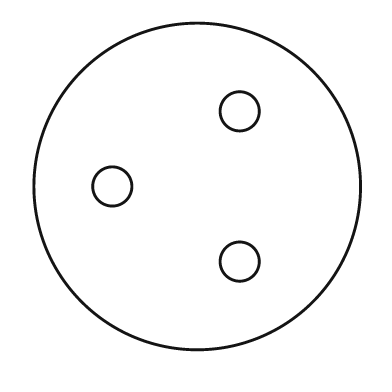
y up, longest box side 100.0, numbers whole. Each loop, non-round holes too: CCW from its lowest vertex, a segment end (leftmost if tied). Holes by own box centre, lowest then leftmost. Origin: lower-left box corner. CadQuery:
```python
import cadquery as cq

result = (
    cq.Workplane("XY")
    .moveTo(50.0, 50.0)
    .circle(50.0)
    .moveTo(63.0, 27.0)
    .circle(6.0)
    .moveTo(24.0, 50.0)
    .circle(6.0)
    .moveTo(63.0, 73.0)
    .circle(6.0)
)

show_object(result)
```